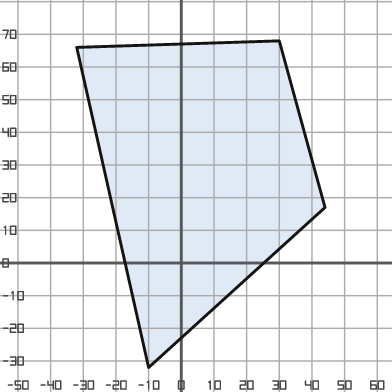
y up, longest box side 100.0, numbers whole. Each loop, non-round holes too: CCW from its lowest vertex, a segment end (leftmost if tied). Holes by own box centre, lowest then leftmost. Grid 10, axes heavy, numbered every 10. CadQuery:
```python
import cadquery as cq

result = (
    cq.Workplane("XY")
    .moveTo(-10.0, -32.0)
    .lineTo(44.0, 17.0)
    .lineTo(30.0, 68.0)
    .lineTo(-32.0, 66.0)
    .close()
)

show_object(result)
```